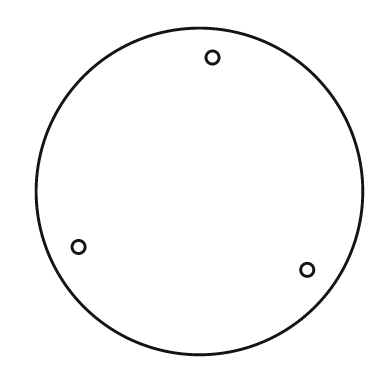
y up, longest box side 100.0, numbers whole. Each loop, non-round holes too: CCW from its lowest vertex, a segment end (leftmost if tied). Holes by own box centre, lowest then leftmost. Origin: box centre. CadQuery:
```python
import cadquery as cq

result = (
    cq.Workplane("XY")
    .moveTo(0.0, 0.0)
    .circle(50.0)
    .moveTo(33.0, -24.0)
    .circle(2.0)
    .moveTo(-37.0, -17.0)
    .circle(2.0)
    .moveTo(4.0, 41.0)
    .circle(2.0)
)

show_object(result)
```